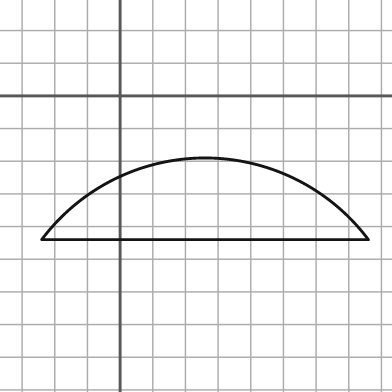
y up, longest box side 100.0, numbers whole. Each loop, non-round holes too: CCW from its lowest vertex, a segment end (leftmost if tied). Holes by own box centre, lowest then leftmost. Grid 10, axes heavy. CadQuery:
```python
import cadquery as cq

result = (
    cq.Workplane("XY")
    .moveTo(-24.0, -44.0)
    .lineTo(76.0, -44.0)
    .threePointArc((26.0, -19.0), (-24.0, -44.0))
    .close()
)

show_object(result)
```